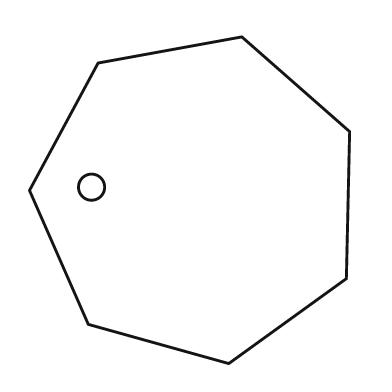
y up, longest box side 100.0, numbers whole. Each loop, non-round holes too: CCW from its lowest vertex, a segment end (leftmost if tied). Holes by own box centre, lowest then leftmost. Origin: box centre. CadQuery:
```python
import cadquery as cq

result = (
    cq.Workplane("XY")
    .moveTo(12.0, -50.0)
    .lineTo(48.0, -24.0)
    .lineTo(49.0, 21.0)
    .lineTo(16.0, 50.0)
    .lineTo(-28.0, 42.0)
    .lineTo(-49.0, 3.0)
    .lineTo(-31.0, -38.0)
    .close()
    .moveTo(-30.0, 4.0)
    .circle(4.0)
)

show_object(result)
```